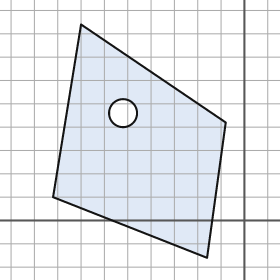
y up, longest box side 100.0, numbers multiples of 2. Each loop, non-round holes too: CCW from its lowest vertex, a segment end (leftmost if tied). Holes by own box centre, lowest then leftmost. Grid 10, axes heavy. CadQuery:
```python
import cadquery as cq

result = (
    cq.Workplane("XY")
    .moveTo(-16.0, -16.0)
    .lineTo(-8.0, 42.0)
    .lineTo(-70.0, 84.0)
    .lineTo(-82.0, 10.0)
    .close()
    .moveTo(-52.0, 46.0)
    .circle(6.0)
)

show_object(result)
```